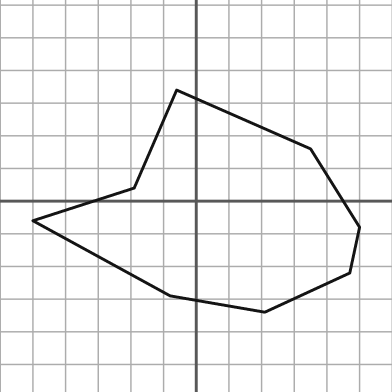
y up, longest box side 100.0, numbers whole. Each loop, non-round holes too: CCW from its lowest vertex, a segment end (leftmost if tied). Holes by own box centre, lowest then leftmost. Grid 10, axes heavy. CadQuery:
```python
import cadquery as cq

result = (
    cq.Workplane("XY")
    .moveTo(21.0, -34.0)
    .lineTo(47.0, -22.0)
    .lineTo(50.0, -8.0)
    .lineTo(35.0, 16.0)
    .lineTo(-6.0, 34.0)
    .lineTo(-19.0, 4.0)
    .lineTo(-50.0, -6.0)
    .lineTo(-8.0, -29.0)
    .close()
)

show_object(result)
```